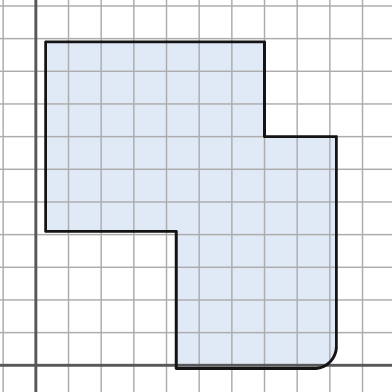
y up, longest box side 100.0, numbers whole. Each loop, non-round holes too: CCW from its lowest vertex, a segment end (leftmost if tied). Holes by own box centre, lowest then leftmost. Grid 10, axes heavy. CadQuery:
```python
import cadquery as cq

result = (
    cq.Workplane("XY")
    .moveTo(43.0, -1.0)
    .lineTo(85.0, -1.0)
    .threePointArc((90.0, 1.0), (92.0, 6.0))
    .lineTo(92.0, 70.0)
    .lineTo(70.0, 70.0)
    .lineTo(70.0, 99.0)
    .lineTo(3.0, 99.0)
    .lineTo(3.0, 41.0)
    .lineTo(43.0, 41.0)
    .close()
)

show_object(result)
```